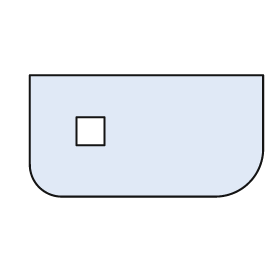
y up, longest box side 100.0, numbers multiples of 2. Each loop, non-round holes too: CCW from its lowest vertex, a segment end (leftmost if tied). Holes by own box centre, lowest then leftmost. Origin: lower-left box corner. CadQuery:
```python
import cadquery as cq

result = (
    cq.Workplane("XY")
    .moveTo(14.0, 0.0)
    .lineTo(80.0, 0.0)
    .threePointArc((94.0, 6.0), (100.0, 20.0))
    .lineTo(100.0, 52.0)
    .lineTo(0.0, 52.0)
    .lineTo(0.0, 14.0)
    .threePointArc((4.0, 4.0), (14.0, 0.0))
    .close()
    .moveTo(20.0, 22.0)
    .lineTo(32.0, 22.0)
    .lineTo(32.0, 34.0)
    .lineTo(20.0, 34.0)
    .close()
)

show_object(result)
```